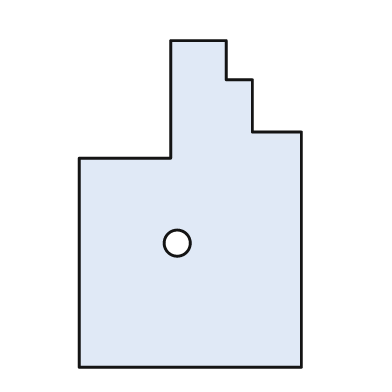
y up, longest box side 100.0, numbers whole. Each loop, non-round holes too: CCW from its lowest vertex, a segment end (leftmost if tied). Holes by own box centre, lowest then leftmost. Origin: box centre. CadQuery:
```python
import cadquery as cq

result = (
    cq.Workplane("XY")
    .moveTo(-34.0, -50.0)
    .lineTo(34.0, -50.0)
    .lineTo(34.0, 22.0)
    .lineTo(19.0, 22.0)
    .lineTo(19.0, 38.0)
    .lineTo(11.0, 38.0)
    .lineTo(11.0, 50.0)
    .lineTo(-6.0, 50.0)
    .lineTo(-6.0, 14.0)
    .lineTo(-34.0, 14.0)
    .close()
    .moveTo(-4.0, -12.0)
    .circle(4.0)
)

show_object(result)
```